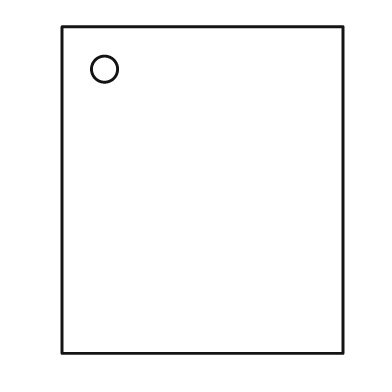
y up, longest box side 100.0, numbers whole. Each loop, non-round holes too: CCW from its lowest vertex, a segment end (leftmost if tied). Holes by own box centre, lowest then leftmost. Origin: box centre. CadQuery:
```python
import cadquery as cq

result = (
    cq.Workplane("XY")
    .moveTo(-43.0, -50.0)
    .lineTo(43.0, -50.0)
    .lineTo(43.0, 50.0)
    .lineTo(-43.0, 50.0)
    .close()
    .moveTo(-30.0, 37.0)
    .circle(4.0)
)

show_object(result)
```